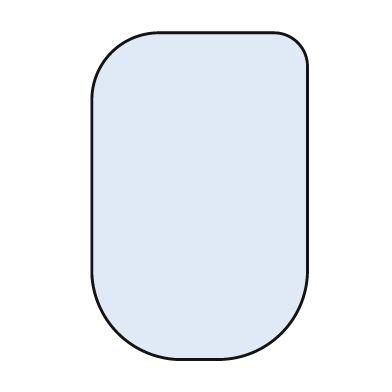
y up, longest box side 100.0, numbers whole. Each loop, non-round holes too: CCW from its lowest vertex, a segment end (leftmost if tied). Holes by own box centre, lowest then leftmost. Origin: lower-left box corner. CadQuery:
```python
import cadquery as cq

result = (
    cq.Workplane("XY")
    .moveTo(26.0, 0.0)
    .lineTo(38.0, 0.0)
    .threePointArc((58.0, 8.0), (66.0, 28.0))
    .lineTo(66.0, 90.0)
    .threePointArc((63.0, 97.0), (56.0, 100.0))
    .lineTo(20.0, 100.0)
    .threePointArc((6.0, 94.0), (0.0, 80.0))
    .lineTo(0.0, 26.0)
    .threePointArc((8.0, 8.0), (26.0, 0.0))
    .close()
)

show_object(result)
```